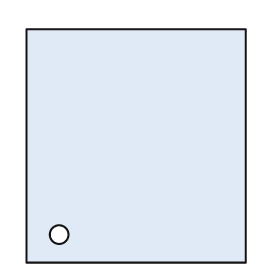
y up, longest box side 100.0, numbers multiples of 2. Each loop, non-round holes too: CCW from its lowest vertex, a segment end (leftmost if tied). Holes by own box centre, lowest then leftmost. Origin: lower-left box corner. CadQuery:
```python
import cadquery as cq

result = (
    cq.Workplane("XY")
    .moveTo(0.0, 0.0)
    .lineTo(94.0, 0.0)
    .lineTo(94.0, 100.0)
    .lineTo(0.0, 100.0)
    .close()
    .moveTo(14.0, 12.0)
    .circle(4.0)
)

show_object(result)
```